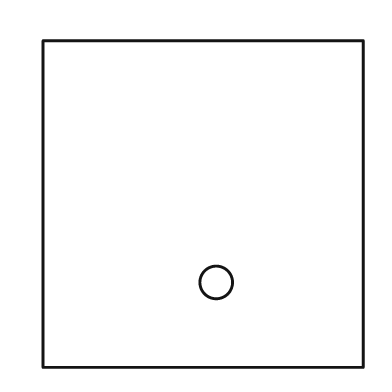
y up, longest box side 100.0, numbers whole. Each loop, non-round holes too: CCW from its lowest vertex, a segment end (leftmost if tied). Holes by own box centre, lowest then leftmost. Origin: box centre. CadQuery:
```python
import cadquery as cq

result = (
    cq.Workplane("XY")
    .moveTo(-49.0, -50.0)
    .lineTo(49.0, -50.0)
    .lineTo(49.0, 50.0)
    .lineTo(-49.0, 50.0)
    .close()
    .moveTo(4.0, -24.0)
    .circle(5.0)
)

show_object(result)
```